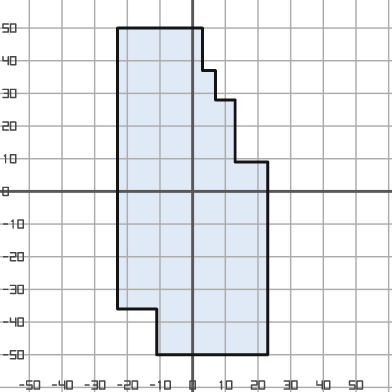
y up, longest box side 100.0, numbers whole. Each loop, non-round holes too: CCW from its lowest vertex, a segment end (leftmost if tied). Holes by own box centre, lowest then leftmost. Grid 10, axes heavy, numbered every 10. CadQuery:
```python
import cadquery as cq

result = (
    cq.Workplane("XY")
    .moveTo(-11.0, -50.0)
    .lineTo(23.0, -50.0)
    .lineTo(23.0, 9.0)
    .lineTo(13.0, 9.0)
    .lineTo(13.0, 28.0)
    .lineTo(7.0, 28.0)
    .lineTo(7.0, 37.0)
    .lineTo(3.0, 37.0)
    .lineTo(3.0, 50.0)
    .lineTo(-23.0, 50.0)
    .lineTo(-23.0, -36.0)
    .lineTo(-11.0, -36.0)
    .close()
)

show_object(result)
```